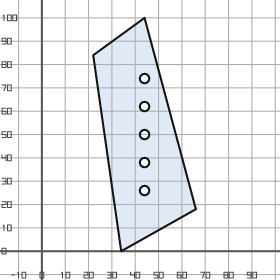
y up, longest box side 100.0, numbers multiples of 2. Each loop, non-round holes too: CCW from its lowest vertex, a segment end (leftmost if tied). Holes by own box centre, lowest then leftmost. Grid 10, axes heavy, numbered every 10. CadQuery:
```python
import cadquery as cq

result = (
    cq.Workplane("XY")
    .moveTo(34.0, 0.0)
    .lineTo(66.0, 18.0)
    .lineTo(44.0, 100.0)
    .lineTo(22.0, 84.0)
    .close()
    .moveTo(44.0, 26.0)
    .circle(2.0)
    .moveTo(44.0, 38.0)
    .circle(2.0)
    .moveTo(44.0, 50.0)
    .circle(2.0)
    .moveTo(44.0, 62.0)
    .circle(2.0)
    .moveTo(44.0, 74.0)
    .circle(2.0)
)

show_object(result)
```